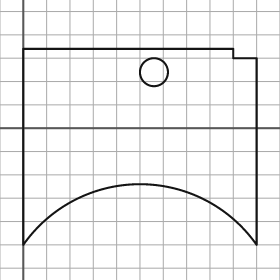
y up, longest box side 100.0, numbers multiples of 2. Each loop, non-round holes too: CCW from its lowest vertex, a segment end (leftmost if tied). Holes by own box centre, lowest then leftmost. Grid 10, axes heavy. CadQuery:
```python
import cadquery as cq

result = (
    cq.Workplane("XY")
    .moveTo(0.0, -50.0)
    .threePointArc((50.0, -24.0), (100.0, -50.0))
    .lineTo(100.0, 30.0)
    .lineTo(90.0, 30.0)
    .lineTo(90.0, 34.0)
    .lineTo(0.0, 34.0)
    .close()
    .moveTo(56.0, 24.0)
    .circle(6.0)
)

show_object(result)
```